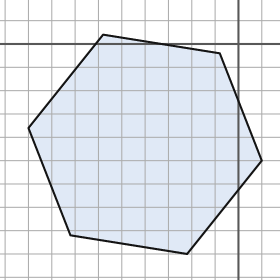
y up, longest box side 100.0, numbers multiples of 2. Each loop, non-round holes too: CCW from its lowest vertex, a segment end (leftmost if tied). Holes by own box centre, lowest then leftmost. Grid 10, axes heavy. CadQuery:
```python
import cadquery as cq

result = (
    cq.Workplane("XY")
    .moveTo(-22.0, -90.0)
    .lineTo(10.0, -50.0)
    .lineTo(-8.0, -4.0)
    .lineTo(-58.0, 4.0)
    .lineTo(-90.0, -36.0)
    .lineTo(-72.0, -82.0)
    .close()
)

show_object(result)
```